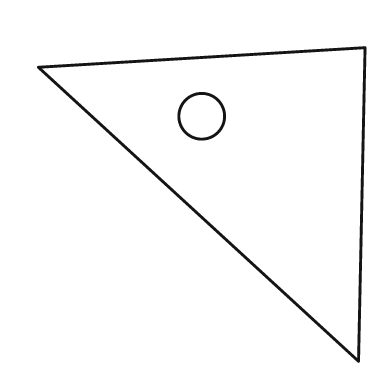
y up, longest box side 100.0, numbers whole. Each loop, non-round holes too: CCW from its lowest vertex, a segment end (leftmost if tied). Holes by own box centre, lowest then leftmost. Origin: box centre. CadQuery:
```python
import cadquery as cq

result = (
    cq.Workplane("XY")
    .moveTo(48.0, -48.0)
    .lineTo(50.0, 48.0)
    .lineTo(-50.0, 42.0)
    .close()
    .moveTo(0.0, 27.0)
    .circle(7.0)
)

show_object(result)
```